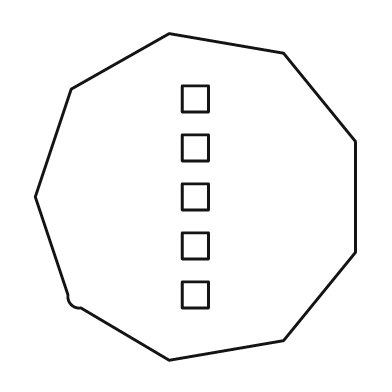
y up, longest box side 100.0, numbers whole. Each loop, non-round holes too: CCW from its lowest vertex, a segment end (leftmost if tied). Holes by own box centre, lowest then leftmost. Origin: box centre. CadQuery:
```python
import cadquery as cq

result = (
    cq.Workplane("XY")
    .moveTo(-8.0, -50.0)
    .lineTo(27.0, -44.0)
    .lineTo(49.0, -17.0)
    .lineTo(49.0, 17.0)
    .lineTo(27.0, 44.0)
    .lineTo(-8.0, 50.0)
    .lineTo(-38.0, 33.0)
    .lineTo(-49.0, 0.0)
    .lineTo(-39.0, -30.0)
    .threePointArc((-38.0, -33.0), (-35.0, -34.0))
    .close()
    .moveTo(-4.0, -34.0)
    .lineTo(4.0, -34.0)
    .lineTo(4.0, -26.0)
    .lineTo(-4.0, -26.0)
    .close()
    .moveTo(-4.0, -19.0)
    .lineTo(4.0, -19.0)
    .lineTo(4.0, -11.0)
    .lineTo(-4.0, -11.0)
    .close()
    .moveTo(-4.0, -4.0)
    .lineTo(4.0, -4.0)
    .lineTo(4.0, 4.0)
    .lineTo(-4.0, 4.0)
    .close()
    .moveTo(-4.0, 11.0)
    .lineTo(4.0, 11.0)
    .lineTo(4.0, 19.0)
    .lineTo(-4.0, 19.0)
    .close()
    .moveTo(-4.0, 26.0)
    .lineTo(4.0, 26.0)
    .lineTo(4.0, 34.0)
    .lineTo(-4.0, 34.0)
    .close()
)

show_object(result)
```